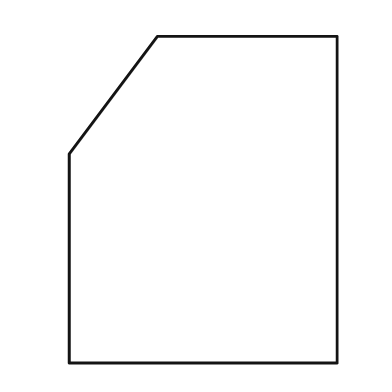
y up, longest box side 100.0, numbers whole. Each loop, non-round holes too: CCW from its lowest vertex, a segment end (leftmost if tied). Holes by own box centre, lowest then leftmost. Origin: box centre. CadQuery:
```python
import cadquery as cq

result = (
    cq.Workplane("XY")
    .moveTo(-41.0, -50.0)
    .lineTo(41.0, -50.0)
    .lineTo(41.0, 50.0)
    .lineTo(-14.0, 50.0)
    .lineTo(-41.0, 14.0)
    .close()
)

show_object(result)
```